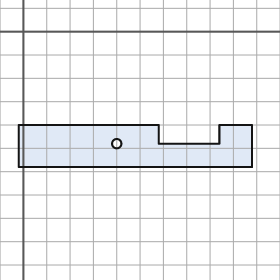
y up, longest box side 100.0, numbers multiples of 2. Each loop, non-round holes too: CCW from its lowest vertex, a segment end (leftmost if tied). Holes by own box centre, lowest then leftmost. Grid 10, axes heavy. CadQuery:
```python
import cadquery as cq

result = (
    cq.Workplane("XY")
    .moveTo(-2.0, -58.0)
    .lineTo(98.0, -58.0)
    .lineTo(98.0, -40.0)
    .lineTo(84.0, -40.0)
    .lineTo(84.0, -48.0)
    .lineTo(58.0, -48.0)
    .lineTo(58.0, -40.0)
    .lineTo(-2.0, -40.0)
    .close()
    .moveTo(40.0, -48.0)
    .circle(2.0)
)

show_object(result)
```